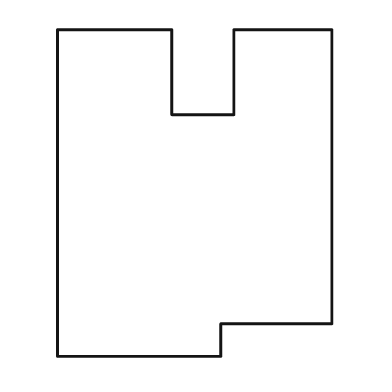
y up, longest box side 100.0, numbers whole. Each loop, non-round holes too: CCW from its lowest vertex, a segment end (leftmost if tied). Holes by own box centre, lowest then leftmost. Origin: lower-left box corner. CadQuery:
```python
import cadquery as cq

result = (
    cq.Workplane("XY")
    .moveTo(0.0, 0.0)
    .lineTo(50.0, 0.0)
    .lineTo(50.0, 10.0)
    .lineTo(84.0, 10.0)
    .lineTo(84.0, 100.0)
    .lineTo(54.0, 100.0)
    .lineTo(54.0, 74.0)
    .lineTo(35.0, 74.0)
    .lineTo(35.0, 100.0)
    .lineTo(0.0, 100.0)
    .close()
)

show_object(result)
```